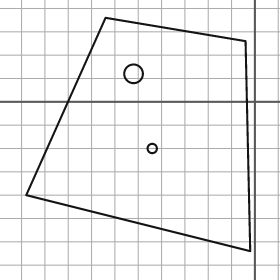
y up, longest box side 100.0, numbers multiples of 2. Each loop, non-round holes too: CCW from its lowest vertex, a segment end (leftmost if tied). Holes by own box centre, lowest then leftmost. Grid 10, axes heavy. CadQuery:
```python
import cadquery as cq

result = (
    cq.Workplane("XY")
    .moveTo(-2.0, -64.0)
    .lineTo(-4.0, 26.0)
    .lineTo(-64.0, 36.0)
    .lineTo(-98.0, -40.0)
    .close()
    .moveTo(-44.0, -20.0)
    .circle(2.0)
    .moveTo(-52.0, 12.0)
    .circle(4.0)
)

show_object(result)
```